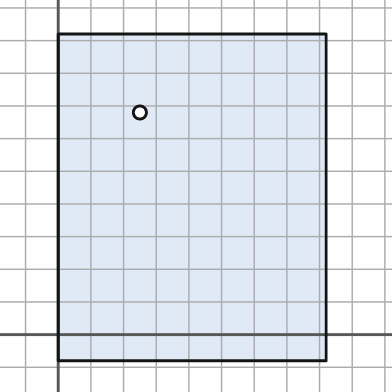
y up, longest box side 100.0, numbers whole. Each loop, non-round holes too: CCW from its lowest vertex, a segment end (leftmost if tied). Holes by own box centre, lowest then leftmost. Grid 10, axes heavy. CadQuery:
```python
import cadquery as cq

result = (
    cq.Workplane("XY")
    .moveTo(0.0, -8.0)
    .lineTo(82.0, -8.0)
    .lineTo(82.0, 92.0)
    .lineTo(0.0, 92.0)
    .close()
    .moveTo(25.0, 68.0)
    .circle(2.0)
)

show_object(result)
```